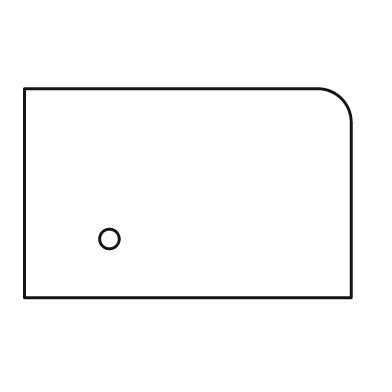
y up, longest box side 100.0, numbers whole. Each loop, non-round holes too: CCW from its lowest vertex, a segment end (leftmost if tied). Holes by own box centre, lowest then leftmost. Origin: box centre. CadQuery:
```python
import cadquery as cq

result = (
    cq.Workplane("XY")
    .moveTo(-50.0, -32.0)
    .lineTo(50.0, -32.0)
    .lineTo(50.0, 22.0)
    .threePointArc((47.0, 29.0), (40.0, 32.0))
    .lineTo(-50.0, 32.0)
    .close()
    .moveTo(-24.0, -14.0)
    .circle(3.0)
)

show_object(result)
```